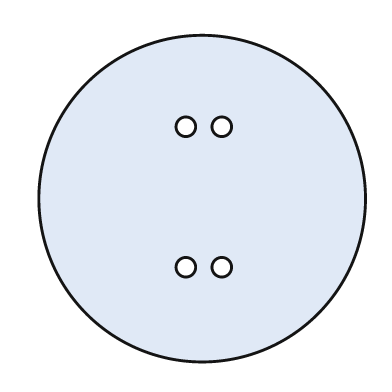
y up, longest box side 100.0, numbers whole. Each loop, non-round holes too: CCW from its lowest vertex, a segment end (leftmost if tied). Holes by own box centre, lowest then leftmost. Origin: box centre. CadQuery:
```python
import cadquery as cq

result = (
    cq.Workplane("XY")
    .moveTo(0.0, 0.0)
    .circle(50.0)
    .moveTo(-5.0, -21.0)
    .circle(3.0)
    .moveTo(6.0, -21.0)
    .circle(3.0)
    .moveTo(-5.0, 22.0)
    .circle(3.0)
    .moveTo(6.0, 22.0)
    .circle(3.0)
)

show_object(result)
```